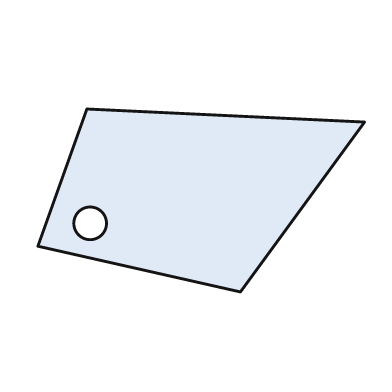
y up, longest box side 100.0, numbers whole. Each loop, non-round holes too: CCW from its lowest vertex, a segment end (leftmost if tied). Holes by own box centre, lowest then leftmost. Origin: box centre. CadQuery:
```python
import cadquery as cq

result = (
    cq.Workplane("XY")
    .moveTo(12.0, -28.0)
    .lineTo(50.0, 24.0)
    .lineTo(-35.0, 28.0)
    .lineTo(-50.0, -14.0)
    .close()
    .moveTo(-34.0, -7.0)
    .circle(5.0)
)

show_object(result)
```